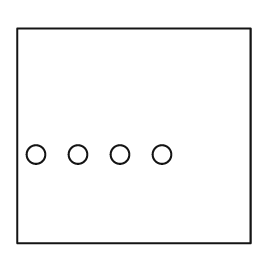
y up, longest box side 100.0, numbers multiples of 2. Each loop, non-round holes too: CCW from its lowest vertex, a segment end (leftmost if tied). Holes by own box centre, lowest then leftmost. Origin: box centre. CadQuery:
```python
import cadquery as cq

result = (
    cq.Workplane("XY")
    .moveTo(-50.0, -46.0)
    .lineTo(50.0, -46.0)
    .lineTo(50.0, 46.0)
    .lineTo(-50.0, 46.0)
    .close()
    .moveTo(-42.0, -8.0)
    .circle(4.0)
    .moveTo(-24.0, -8.0)
    .circle(4.0)
    .moveTo(-6.0, -8.0)
    .circle(4.0)
    .moveTo(12.0, -8.0)
    .circle(4.0)
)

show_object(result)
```